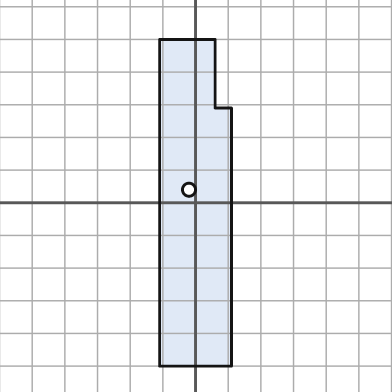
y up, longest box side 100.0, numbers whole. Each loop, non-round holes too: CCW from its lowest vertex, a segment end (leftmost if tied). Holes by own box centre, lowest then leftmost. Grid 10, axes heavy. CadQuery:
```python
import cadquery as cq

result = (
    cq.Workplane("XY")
    .moveTo(-11.0, -50.0)
    .lineTo(11.0, -50.0)
    .lineTo(11.0, 29.0)
    .lineTo(6.0, 29.0)
    .lineTo(6.0, 50.0)
    .lineTo(-11.0, 50.0)
    .close()
    .moveTo(-2.0, 4.0)
    .circle(2.0)
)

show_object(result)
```